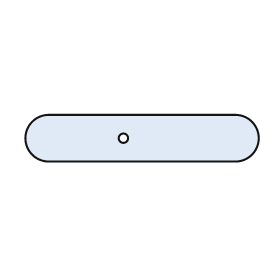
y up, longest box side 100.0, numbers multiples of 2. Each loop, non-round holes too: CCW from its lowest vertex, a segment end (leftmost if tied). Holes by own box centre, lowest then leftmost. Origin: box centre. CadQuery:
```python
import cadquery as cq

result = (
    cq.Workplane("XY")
    .moveTo(-40.0, -10.0)
    .lineTo(40.0, -10.0)
    .threePointArc((50.0, 0.0), (40.0, 10.0))
    .lineTo(-40.0, 10.0)
    .threePointArc((-50.0, 0.0), (-40.0, -10.0))
    .close()
    .moveTo(-8.0, 0.0)
    .circle(2.0)
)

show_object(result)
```